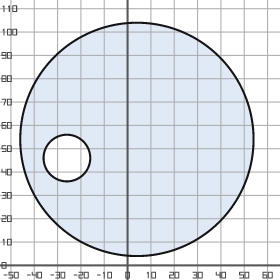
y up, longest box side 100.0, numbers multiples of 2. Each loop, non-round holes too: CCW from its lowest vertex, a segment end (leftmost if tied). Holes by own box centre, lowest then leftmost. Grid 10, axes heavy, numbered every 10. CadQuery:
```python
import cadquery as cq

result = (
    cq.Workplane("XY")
    .moveTo(4.0, 54.0)
    .circle(50.0)
    .moveTo(-26.0, 46.0)
    .circle(10.0)
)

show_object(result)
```